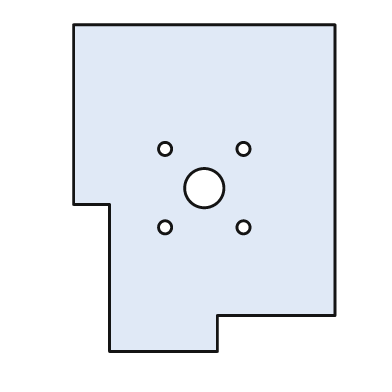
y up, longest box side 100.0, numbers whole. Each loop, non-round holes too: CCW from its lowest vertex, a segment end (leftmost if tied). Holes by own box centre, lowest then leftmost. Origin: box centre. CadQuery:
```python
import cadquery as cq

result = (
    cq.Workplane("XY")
    .moveTo(-29.0, -50.0)
    .lineTo(4.0, -50.0)
    .lineTo(4.0, -39.0)
    .lineTo(40.0, -39.0)
    .lineTo(40.0, 50.0)
    .lineTo(-40.0, 50.0)
    .lineTo(-40.0, -5.0)
    .lineTo(-29.0, -5.0)
    .close()
    .moveTo(-12.0, -12.0)
    .circle(2.0)
    .moveTo(12.0, -12.0)
    .circle(2.0)
    .moveTo(0.0, 0.0)
    .circle(6.0)
    .moveTo(-12.0, 12.0)
    .circle(2.0)
    .moveTo(12.0, 12.0)
    .circle(2.0)
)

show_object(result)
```